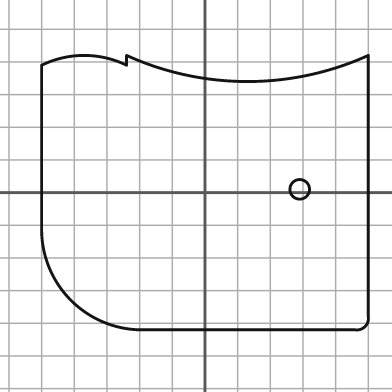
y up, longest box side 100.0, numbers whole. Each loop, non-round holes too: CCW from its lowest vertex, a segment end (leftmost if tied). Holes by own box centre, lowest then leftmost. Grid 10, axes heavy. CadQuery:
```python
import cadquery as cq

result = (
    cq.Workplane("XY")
    .moveTo(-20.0, -42.0)
    .lineTo(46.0, -42.0)
    .threePointArc((49.0, -41.0), (50.0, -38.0))
    .lineTo(50.0, 42.0)
    .threePointArc((13.0, 34.0), (-24.0, 42.0))
    .lineTo(-24.0, 39.0)
    .threePointArc((-37.0, 42.0), (-50.0, 39.0))
    .lineTo(-50.0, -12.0)
    .threePointArc((-41.0, -33.0), (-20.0, -42.0))
    .close()
    .moveTo(29.0, 1.0)
    .circle(3.0)
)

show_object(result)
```